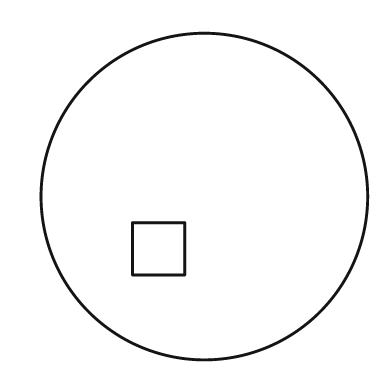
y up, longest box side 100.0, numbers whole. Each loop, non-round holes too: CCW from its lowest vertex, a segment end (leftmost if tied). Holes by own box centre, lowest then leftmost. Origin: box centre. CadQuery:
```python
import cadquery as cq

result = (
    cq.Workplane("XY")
    .moveTo(0.0, 0.0)
    .circle(50.0)
    .moveTo(-22.0, -24.0)
    .lineTo(-6.0, -24.0)
    .lineTo(-6.0, -8.0)
    .lineTo(-22.0, -8.0)
    .close()
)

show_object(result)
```